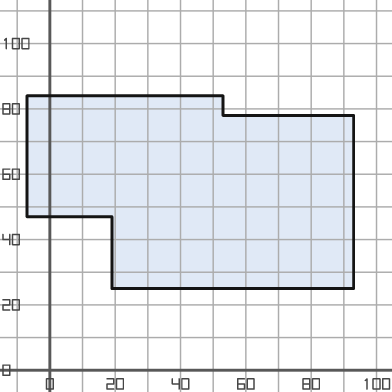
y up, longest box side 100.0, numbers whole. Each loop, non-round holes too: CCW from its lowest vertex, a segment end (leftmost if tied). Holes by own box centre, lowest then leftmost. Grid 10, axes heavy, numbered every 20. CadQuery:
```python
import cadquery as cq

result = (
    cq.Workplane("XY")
    .moveTo(19.0, 25.0)
    .lineTo(93.0, 25.0)
    .lineTo(93.0, 78.0)
    .lineTo(53.0, 78.0)
    .lineTo(53.0, 84.0)
    .lineTo(-7.0, 84.0)
    .lineTo(-7.0, 47.0)
    .lineTo(19.0, 47.0)
    .close()
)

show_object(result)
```